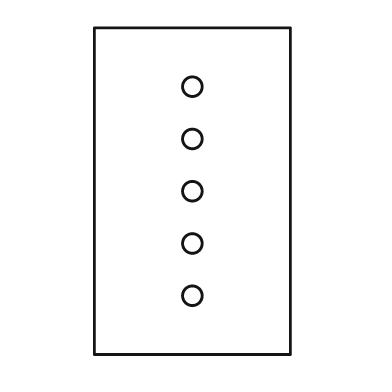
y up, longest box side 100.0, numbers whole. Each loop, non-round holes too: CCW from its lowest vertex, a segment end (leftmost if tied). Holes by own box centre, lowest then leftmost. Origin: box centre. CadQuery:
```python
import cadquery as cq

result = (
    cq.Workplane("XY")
    .moveTo(-30.0, -50.0)
    .lineTo(30.0, -50.0)
    .lineTo(30.0, 50.0)
    .lineTo(-30.0, 50.0)
    .close()
    .moveTo(0.0, -32.0)
    .circle(3.0)
    .moveTo(0.0, -16.0)
    .circle(3.0)
    .moveTo(0.0, 0.0)
    .circle(3.0)
    .moveTo(0.0, 16.0)
    .circle(3.0)
    .moveTo(0.0, 32.0)
    .circle(3.0)
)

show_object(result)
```